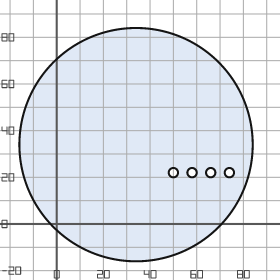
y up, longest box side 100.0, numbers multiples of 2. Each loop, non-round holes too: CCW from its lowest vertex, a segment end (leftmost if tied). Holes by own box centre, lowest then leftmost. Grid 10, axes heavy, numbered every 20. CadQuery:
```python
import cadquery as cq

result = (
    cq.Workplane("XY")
    .moveTo(34.0, 34.0)
    .circle(50.0)
    .moveTo(50.0, 22.0)
    .circle(2.0)
    .moveTo(58.0, 22.0)
    .circle(2.0)
    .moveTo(66.0, 22.0)
    .circle(2.0)
    .moveTo(74.0, 22.0)
    .circle(2.0)
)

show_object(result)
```